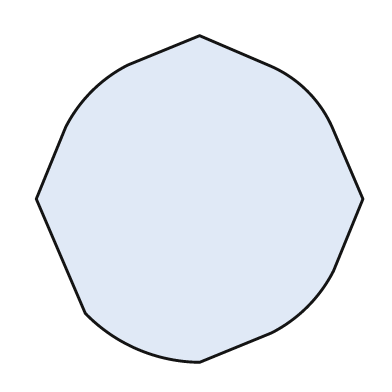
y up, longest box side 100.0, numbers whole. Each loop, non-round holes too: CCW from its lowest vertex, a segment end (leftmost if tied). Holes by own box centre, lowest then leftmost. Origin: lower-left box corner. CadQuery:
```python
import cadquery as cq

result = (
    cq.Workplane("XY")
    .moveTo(50.0, 0.0)
    .lineTo(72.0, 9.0)
    .threePointArc((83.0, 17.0), (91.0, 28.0))
    .lineTo(100.0, 50.0)
    .lineTo(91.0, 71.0)
    .threePointArc((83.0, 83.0), (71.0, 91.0))
    .lineTo(50.0, 100.0)
    .lineTo(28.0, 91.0)
    .threePointArc((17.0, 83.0), (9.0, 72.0))
    .lineTo(0.0, 50.0)
    .lineTo(15.0, 15.0)
    .threePointArc((31.0, 4.0), (50.0, 0.0))
    .close()
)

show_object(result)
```